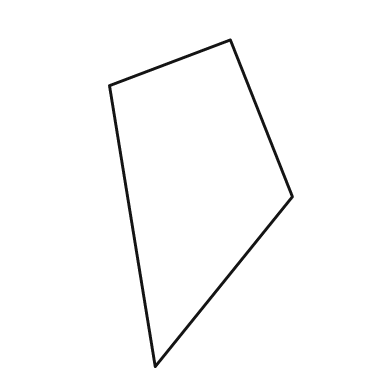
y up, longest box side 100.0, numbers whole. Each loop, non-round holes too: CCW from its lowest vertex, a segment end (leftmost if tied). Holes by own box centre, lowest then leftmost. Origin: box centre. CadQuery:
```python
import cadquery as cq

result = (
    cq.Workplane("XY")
    .moveTo(-14.0, -50.0)
    .lineTo(28.0, 2.0)
    .lineTo(9.0, 50.0)
    .lineTo(-28.0, 36.0)
    .close()
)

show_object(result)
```